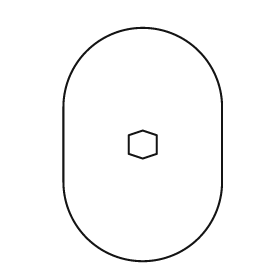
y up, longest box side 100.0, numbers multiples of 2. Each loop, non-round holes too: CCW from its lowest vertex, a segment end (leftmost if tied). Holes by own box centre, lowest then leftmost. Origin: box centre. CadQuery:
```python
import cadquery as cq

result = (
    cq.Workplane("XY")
    .moveTo(-34.0, -16.0)
    .threePointArc((0.0, -50.0), (34.0, -16.0))
    .lineTo(34.0, 16.0)
    .threePointArc((0.0, 50.0), (-34.0, 16.0))
    .close()
    .moveTo(0.0, -6.0)
    .lineTo(6.0, -4.0)
    .lineTo(6.0, 4.0)
    .lineTo(0.0, 6.0)
    .lineTo(-6.0, 4.0)
    .lineTo(-6.0, -4.0)
    .close()
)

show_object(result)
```